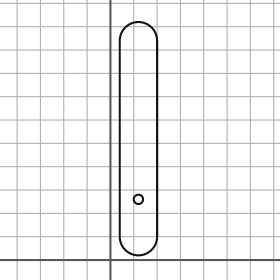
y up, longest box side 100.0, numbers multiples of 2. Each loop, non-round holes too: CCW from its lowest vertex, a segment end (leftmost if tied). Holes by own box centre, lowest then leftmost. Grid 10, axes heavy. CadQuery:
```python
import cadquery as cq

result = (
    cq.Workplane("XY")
    .moveTo(4.0, 10.0)
    .threePointArc((12.0, 2.0), (20.0, 10.0))
    .lineTo(20.0, 94.0)
    .threePointArc((12.0, 102.0), (4.0, 94.0))
    .close()
    .moveTo(12.0, 26.0)
    .circle(2.0)
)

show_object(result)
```